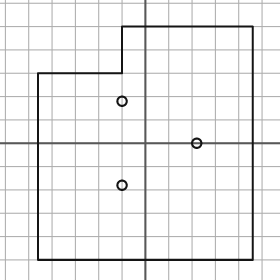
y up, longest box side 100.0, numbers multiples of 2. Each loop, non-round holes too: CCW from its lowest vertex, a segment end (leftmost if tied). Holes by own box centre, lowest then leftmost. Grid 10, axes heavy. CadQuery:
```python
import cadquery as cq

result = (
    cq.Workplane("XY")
    .moveTo(-46.0, -50.0)
    .lineTo(46.0, -50.0)
    .lineTo(46.0, 50.0)
    .lineTo(-10.0, 50.0)
    .lineTo(-10.0, 30.0)
    .lineTo(-46.0, 30.0)
    .close()
    .moveTo(-10.0, -18.0)
    .circle(2.0)
    .moveTo(22.0, 0.0)
    .circle(2.0)
    .moveTo(-10.0, 18.0)
    .circle(2.0)
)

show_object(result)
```